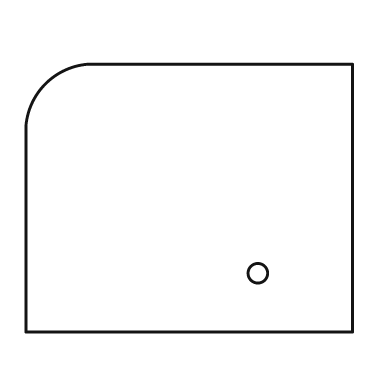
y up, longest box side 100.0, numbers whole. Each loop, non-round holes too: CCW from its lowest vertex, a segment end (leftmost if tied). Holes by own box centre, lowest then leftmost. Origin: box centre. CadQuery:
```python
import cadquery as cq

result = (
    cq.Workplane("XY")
    .moveTo(-50.0, -41.0)
    .lineTo(50.0, -41.0)
    .lineTo(50.0, 41.0)
    .lineTo(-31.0, 41.0)
    .threePointArc((-44.0, 35.0), (-50.0, 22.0))
    .close()
    .moveTo(21.0, -23.0)
    .circle(3.0)
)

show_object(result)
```